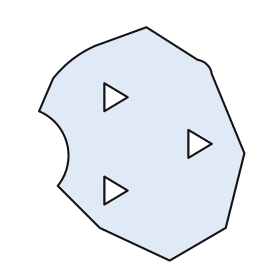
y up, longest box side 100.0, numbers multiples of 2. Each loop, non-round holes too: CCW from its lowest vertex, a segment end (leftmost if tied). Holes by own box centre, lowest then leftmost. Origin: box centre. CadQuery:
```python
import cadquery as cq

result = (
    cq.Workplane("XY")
    .moveTo(12.0, -50.0)
    .lineTo(36.0, -36.0)
    .lineTo(44.0, -4.0)
    .lineTo(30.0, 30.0)
    .threePointArc((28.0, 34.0), (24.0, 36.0))
    .lineTo(2.0, 50.0)
    .lineTo(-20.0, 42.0)
    .threePointArc((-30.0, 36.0), (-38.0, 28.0))
    .lineTo(-44.0, 14.0)
    .threePointArc((-32.0, 0.0), (-36.0, -18.0))
    .lineTo(-18.0, -36.0)
    .close()
    .moveTo(-16.0, -26.0)
    .lineTo(-6.0, -20.0)
    .lineTo(-16.0, -14.0)
    .close()
    .moveTo(20.0, -6.0)
    .lineTo(30.0, 0.0)
    .lineTo(20.0, 6.0)
    .close()
    .moveTo(-16.0, 14.0)
    .lineTo(-6.0, 20.0)
    .lineTo(-16.0, 26.0)
    .close()
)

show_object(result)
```